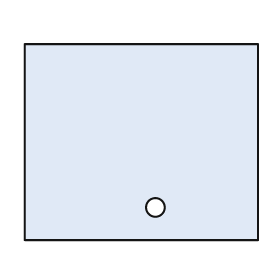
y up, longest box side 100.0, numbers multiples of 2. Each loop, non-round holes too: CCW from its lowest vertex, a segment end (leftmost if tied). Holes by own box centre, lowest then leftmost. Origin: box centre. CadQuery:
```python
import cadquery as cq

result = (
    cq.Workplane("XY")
    .moveTo(-50.0, -42.0)
    .lineTo(50.0, -42.0)
    .lineTo(50.0, 42.0)
    .lineTo(-50.0, 42.0)
    .close()
    .moveTo(6.0, -28.0)
    .circle(4.0)
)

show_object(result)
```